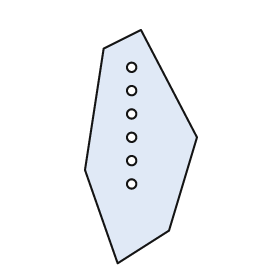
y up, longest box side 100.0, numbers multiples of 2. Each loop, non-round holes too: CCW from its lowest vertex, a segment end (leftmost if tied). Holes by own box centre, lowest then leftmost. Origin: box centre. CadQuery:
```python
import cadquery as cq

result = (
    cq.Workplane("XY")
    .moveTo(-10.0, -50.0)
    .lineTo(12.0, -36.0)
    .lineTo(24.0, 4.0)
    .lineTo(0.0, 50.0)
    .lineTo(-16.0, 42.0)
    .lineTo(-24.0, -10.0)
    .close()
    .moveTo(-4.0, -16.0)
    .circle(2.0)
    .moveTo(-4.0, -6.0)
    .circle(2.0)
    .moveTo(-4.0, 4.0)
    .circle(2.0)
    .moveTo(-4.0, 14.0)
    .circle(2.0)
    .moveTo(-4.0, 24.0)
    .circle(2.0)
    .moveTo(-4.0, 34.0)
    .circle(2.0)
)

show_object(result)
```